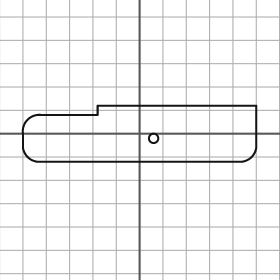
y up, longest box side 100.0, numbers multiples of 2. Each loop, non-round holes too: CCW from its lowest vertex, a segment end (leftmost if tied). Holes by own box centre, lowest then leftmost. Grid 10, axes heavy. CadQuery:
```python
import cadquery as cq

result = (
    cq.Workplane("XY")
    .moveTo(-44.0, -12.0)
    .lineTo(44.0, -12.0)
    .threePointArc((48.0, -10.0), (50.0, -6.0))
    .lineTo(50.0, 12.0)
    .lineTo(-18.0, 12.0)
    .lineTo(-18.0, 8.0)
    .lineTo(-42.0, 8.0)
    .threePointArc((-48.0, 6.0), (-50.0, 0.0))
    .lineTo(-50.0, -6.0)
    .threePointArc((-48.0, -10.0), (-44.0, -12.0))
    .close()
    .moveTo(6.0, -2.0)
    .circle(2.0)
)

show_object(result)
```